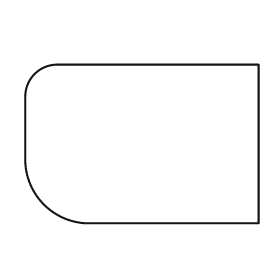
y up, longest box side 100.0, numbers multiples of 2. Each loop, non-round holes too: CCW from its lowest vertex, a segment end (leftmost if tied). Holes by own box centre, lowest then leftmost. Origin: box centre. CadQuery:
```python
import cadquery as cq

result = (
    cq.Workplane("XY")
    .moveTo(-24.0, -34.0)
    .lineTo(50.0, -34.0)
    .lineTo(50.0, 34.0)
    .lineTo(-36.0, 34.0)
    .threePointArc((-46.0, 30.0), (-50.0, 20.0))
    .lineTo(-50.0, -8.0)
    .threePointArc((-42.0, -26.0), (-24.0, -34.0))
    .close()
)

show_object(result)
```